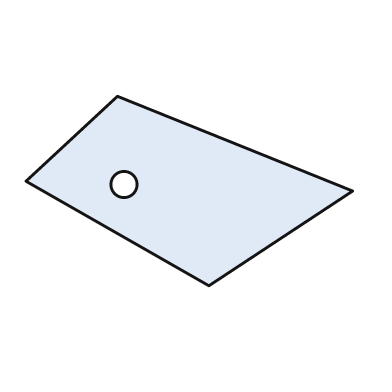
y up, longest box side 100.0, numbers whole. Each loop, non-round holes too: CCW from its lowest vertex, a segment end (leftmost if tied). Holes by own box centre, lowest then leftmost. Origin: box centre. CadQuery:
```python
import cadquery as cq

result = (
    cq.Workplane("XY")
    .moveTo(6.0, -29.0)
    .lineTo(50.0, 0.0)
    .lineTo(-22.0, 29.0)
    .lineTo(-50.0, 3.0)
    .close()
    .moveTo(-20.0, 2.0)
    .circle(4.0)
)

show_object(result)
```